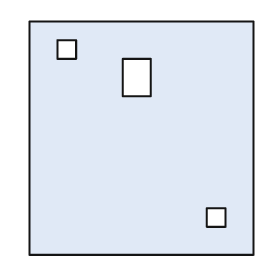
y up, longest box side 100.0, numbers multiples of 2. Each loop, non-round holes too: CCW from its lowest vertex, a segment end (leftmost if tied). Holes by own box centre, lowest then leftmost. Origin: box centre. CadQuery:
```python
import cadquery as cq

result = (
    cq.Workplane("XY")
    .moveTo(-48.0, -50.0)
    .lineTo(48.0, -50.0)
    .lineTo(48.0, 50.0)
    .lineTo(-48.0, 50.0)
    .close()
    .moveTo(28.0, -38.0)
    .lineTo(36.0, -38.0)
    .lineTo(36.0, -30.0)
    .lineTo(28.0, -30.0)
    .close()
    .moveTo(-8.0, 18.0)
    .lineTo(4.0, 18.0)
    .lineTo(4.0, 34.0)
    .lineTo(-8.0, 34.0)
    .close()
    .moveTo(-36.0, 34.0)
    .lineTo(-28.0, 34.0)
    .lineTo(-28.0, 42.0)
    .lineTo(-36.0, 42.0)
    .close()
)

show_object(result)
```